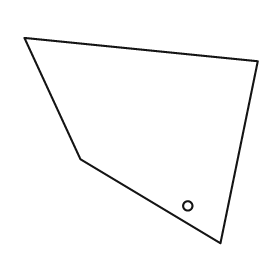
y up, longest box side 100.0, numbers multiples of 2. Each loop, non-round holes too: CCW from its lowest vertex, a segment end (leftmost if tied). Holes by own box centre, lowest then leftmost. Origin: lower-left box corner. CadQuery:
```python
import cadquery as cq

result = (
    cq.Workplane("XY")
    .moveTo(84.0, 0.0)
    .lineTo(100.0, 78.0)
    .lineTo(0.0, 88.0)
    .lineTo(24.0, 36.0)
    .close()
    .moveTo(70.0, 16.0)
    .circle(2.0)
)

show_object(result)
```